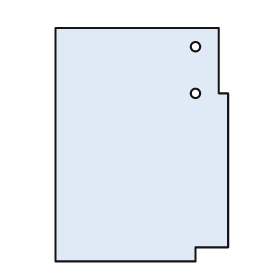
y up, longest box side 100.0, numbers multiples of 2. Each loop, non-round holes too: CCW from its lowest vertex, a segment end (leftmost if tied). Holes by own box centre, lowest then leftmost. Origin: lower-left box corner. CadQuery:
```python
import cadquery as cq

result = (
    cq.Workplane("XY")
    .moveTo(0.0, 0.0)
    .lineTo(60.0, 0.0)
    .lineTo(60.0, 6.0)
    .lineTo(74.0, 6.0)
    .lineTo(74.0, 72.0)
    .lineTo(70.0, 72.0)
    .lineTo(70.0, 100.0)
    .lineTo(0.0, 100.0)
    .close()
    .moveTo(60.0, 72.0)
    .circle(2.0)
    .moveTo(60.0, 92.0)
    .circle(2.0)
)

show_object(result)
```